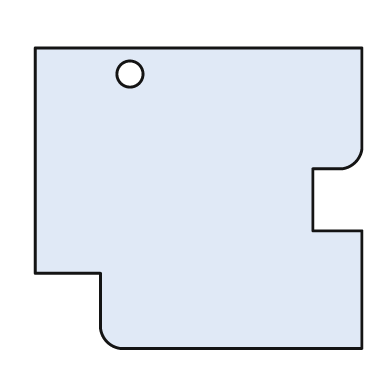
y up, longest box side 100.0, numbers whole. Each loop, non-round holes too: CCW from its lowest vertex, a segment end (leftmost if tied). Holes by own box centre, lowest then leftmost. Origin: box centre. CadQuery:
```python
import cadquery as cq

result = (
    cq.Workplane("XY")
    .moveTo(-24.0, -46.0)
    .lineTo(50.0, -46.0)
    .lineTo(50.0, -10.0)
    .lineTo(35.0, -10.0)
    .lineTo(35.0, 9.0)
    .lineTo(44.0, 9.0)
    .threePointArc((48.0, 11.0), (50.0, 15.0))
    .lineTo(50.0, 46.0)
    .lineTo(-50.0, 46.0)
    .lineTo(-50.0, -23.0)
    .lineTo(-30.0, -23.0)
    .lineTo(-30.0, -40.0)
    .threePointArc((-28.0, -44.0), (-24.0, -46.0))
    .close()
    .moveTo(-21.0, 38.0)
    .circle(4.0)
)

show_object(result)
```